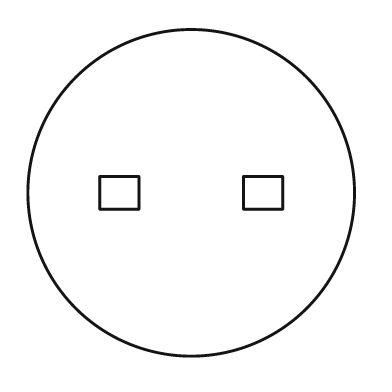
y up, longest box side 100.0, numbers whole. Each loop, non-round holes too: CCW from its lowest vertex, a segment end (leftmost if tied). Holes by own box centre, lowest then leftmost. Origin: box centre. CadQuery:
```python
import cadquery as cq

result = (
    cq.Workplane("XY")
    .moveTo(0.0, 0.0)
    .circle(50.0)
    .moveTo(-28.0, -5.0)
    .lineTo(-16.0, -5.0)
    .lineTo(-16.0, 5.0)
    .lineTo(-28.0, 5.0)
    .close()
    .moveTo(16.0, -5.0)
    .lineTo(28.0, -5.0)
    .lineTo(28.0, 5.0)
    .lineTo(16.0, 5.0)
    .close()
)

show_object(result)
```